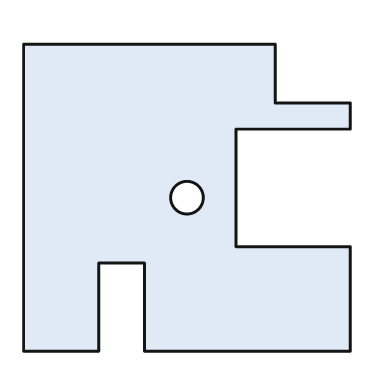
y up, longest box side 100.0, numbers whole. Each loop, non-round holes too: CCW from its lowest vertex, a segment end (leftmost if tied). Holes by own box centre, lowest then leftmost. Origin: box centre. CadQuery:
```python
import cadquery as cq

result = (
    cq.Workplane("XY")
    .moveTo(-50.0, -47.0)
    .lineTo(-27.0, -47.0)
    .lineTo(-27.0, -20.0)
    .lineTo(-13.0, -20.0)
    .lineTo(-13.0, -47.0)
    .lineTo(50.0, -47.0)
    .lineTo(50.0, -15.0)
    .lineTo(15.0, -15.0)
    .lineTo(15.0, 21.0)
    .lineTo(50.0, 21.0)
    .lineTo(50.0, 29.0)
    .lineTo(27.0, 29.0)
    .lineTo(27.0, 47.0)
    .lineTo(-50.0, 47.0)
    .close()
    .moveTo(0.0, 0.0)
    .circle(5.0)
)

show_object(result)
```